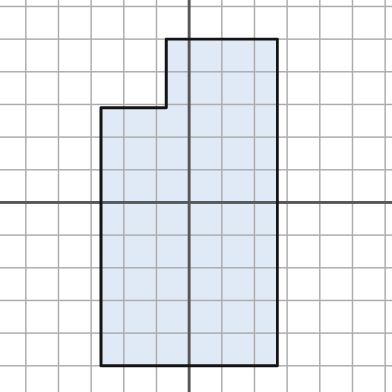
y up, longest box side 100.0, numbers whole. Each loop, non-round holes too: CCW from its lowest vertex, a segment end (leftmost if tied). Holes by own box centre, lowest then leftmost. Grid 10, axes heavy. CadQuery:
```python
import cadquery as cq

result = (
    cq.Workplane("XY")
    .moveTo(-27.0, -50.0)
    .lineTo(27.0, -50.0)
    .lineTo(27.0, 50.0)
    .lineTo(-7.0, 50.0)
    .lineTo(-7.0, 29.0)
    .lineTo(-27.0, 29.0)
    .close()
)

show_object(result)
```